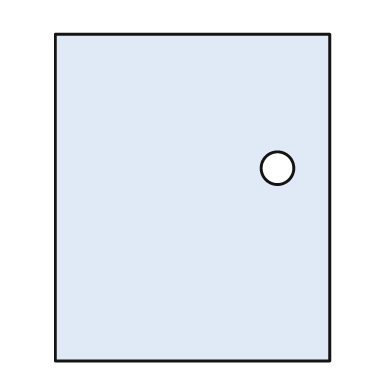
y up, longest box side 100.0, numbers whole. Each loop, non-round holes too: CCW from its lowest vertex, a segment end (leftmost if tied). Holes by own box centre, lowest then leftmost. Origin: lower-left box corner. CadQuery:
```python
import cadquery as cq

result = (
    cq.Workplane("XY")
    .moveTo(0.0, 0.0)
    .lineTo(84.0, 0.0)
    .lineTo(84.0, 100.0)
    .lineTo(0.0, 100.0)
    .close()
    .moveTo(68.0, 59.0)
    .circle(5.0)
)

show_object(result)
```